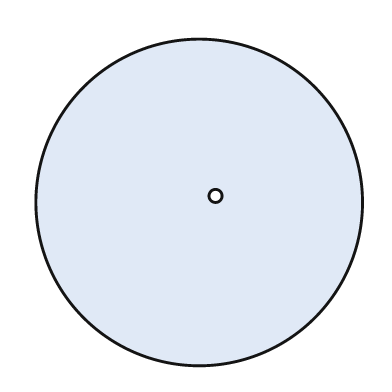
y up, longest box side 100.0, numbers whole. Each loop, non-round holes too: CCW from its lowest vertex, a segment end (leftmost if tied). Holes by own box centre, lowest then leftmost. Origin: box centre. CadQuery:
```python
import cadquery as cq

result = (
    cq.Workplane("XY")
    .moveTo(0.0, 0.0)
    .circle(50.0)
    .moveTo(5.0, 2.0)
    .circle(2.0)
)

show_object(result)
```